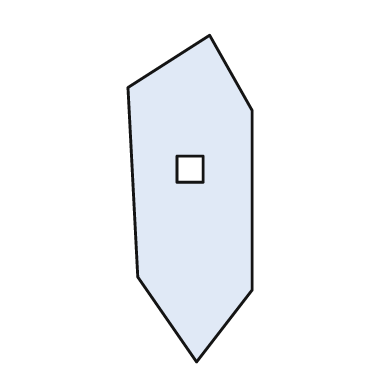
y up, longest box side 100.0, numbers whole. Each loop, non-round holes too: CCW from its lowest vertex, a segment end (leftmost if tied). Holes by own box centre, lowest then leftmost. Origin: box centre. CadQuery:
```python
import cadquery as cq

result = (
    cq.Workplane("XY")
    .moveTo(2.0, -50.0)
    .lineTo(19.0, -28.0)
    .lineTo(19.0, 27.0)
    .lineTo(6.0, 50.0)
    .lineTo(-19.0, 34.0)
    .lineTo(-16.0, -24.0)
    .close()
    .moveTo(-4.0, 5.0)
    .lineTo(4.0, 5.0)
    .lineTo(4.0, 13.0)
    .lineTo(-4.0, 13.0)
    .close()
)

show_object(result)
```